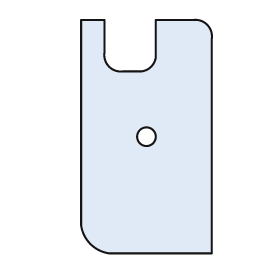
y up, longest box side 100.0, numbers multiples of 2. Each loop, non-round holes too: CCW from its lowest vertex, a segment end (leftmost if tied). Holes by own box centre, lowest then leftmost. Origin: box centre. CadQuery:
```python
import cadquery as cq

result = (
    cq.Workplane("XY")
    .moveTo(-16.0, -50.0)
    .lineTo(28.0, -50.0)
    .lineTo(28.0, 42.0)
    .threePointArc((26.0, 48.0), (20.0, 50.0))
    .lineTo(4.0, 50.0)
    .lineTo(4.0, 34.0)
    .threePointArc((2.0, 30.0), (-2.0, 28.0))
    .lineTo(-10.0, 28.0)
    .threePointArc((-16.0, 30.0), (-18.0, 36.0))
    .lineTo(-18.0, 50.0)
    .lineTo(-28.0, 50.0)
    .lineTo(-28.0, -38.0)
    .threePointArc((-24.0, -46.0), (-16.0, -50.0))
    .close()
    .moveTo(0.0, 0.0)
    .circle(4.0)
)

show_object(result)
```